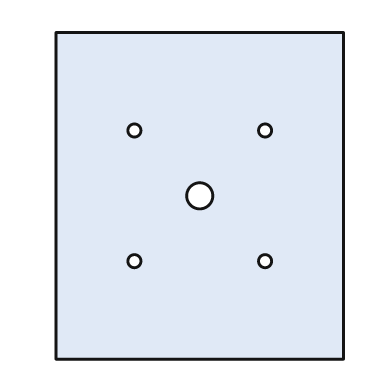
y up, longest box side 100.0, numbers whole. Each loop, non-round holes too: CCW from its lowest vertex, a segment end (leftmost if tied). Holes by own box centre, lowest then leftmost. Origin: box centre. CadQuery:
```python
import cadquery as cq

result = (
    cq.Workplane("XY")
    .moveTo(-44.0, -50.0)
    .lineTo(44.0, -50.0)
    .lineTo(44.0, 50.0)
    .lineTo(-44.0, 50.0)
    .close()
    .moveTo(-20.0, -20.0)
    .circle(2.0)
    .moveTo(20.0, -20.0)
    .circle(2.0)
    .moveTo(0.0, 0.0)
    .circle(4.0)
    .moveTo(-20.0, 20.0)
    .circle(2.0)
    .moveTo(20.0, 20.0)
    .circle(2.0)
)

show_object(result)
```